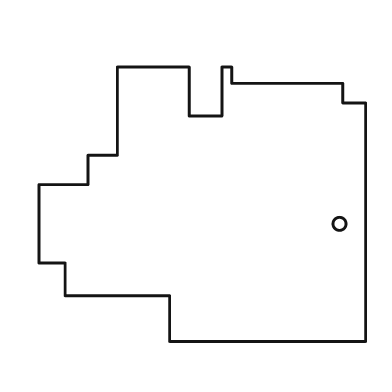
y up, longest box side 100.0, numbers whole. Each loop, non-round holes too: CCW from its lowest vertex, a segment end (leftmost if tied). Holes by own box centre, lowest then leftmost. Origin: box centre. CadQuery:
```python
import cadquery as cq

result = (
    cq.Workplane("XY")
    .moveTo(-10.0, -42.0)
    .lineTo(50.0, -42.0)
    .lineTo(50.0, 31.0)
    .lineTo(43.0, 31.0)
    .lineTo(43.0, 37.0)
    .lineTo(9.0, 37.0)
    .lineTo(9.0, 42.0)
    .lineTo(6.0, 42.0)
    .lineTo(6.0, 27.0)
    .lineTo(-4.0, 27.0)
    .lineTo(-4.0, 42.0)
    .lineTo(-26.0, 42.0)
    .lineTo(-26.0, 15.0)
    .lineTo(-35.0, 15.0)
    .lineTo(-35.0, 6.0)
    .lineTo(-50.0, 6.0)
    .lineTo(-50.0, -18.0)
    .lineTo(-42.0, -18.0)
    .lineTo(-42.0, -28.0)
    .lineTo(-10.0, -28.0)
    .close()
    .moveTo(42.0, -6.0)
    .circle(2.0)
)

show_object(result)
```